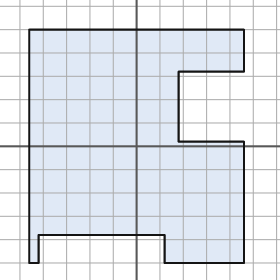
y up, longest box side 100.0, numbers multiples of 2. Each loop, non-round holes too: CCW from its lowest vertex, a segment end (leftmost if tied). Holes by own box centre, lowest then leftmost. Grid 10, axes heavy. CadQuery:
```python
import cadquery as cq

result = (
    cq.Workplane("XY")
    .moveTo(-46.0, -50.0)
    .lineTo(-42.0, -50.0)
    .lineTo(-42.0, -38.0)
    .lineTo(12.0, -38.0)
    .lineTo(12.0, -50.0)
    .lineTo(46.0, -50.0)
    .lineTo(46.0, 2.0)
    .lineTo(18.0, 2.0)
    .lineTo(18.0, 32.0)
    .lineTo(46.0, 32.0)
    .lineTo(46.0, 50.0)
    .lineTo(-46.0, 50.0)
    .close()
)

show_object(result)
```